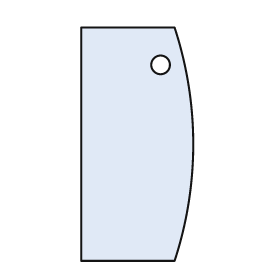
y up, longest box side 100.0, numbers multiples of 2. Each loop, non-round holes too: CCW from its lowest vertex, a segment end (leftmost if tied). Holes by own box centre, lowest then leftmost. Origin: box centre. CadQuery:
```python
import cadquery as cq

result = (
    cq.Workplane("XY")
    .moveTo(-24.0, -50.0)
    .lineTo(16.0, -50.0)
    .threePointArc((24.0, 0.0), (16.0, 50.0))
    .lineTo(-24.0, 50.0)
    .close()
    .moveTo(10.0, 34.0)
    .circle(4.0)
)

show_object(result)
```